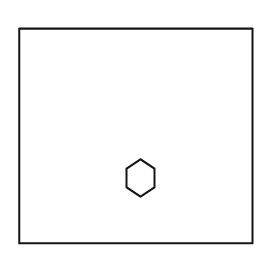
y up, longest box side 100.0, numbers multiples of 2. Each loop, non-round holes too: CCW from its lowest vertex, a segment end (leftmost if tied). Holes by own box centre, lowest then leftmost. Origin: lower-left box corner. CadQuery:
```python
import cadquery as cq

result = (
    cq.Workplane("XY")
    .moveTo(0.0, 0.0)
    .lineTo(100.0, 0.0)
    .lineTo(100.0, 92.0)
    .lineTo(0.0, 92.0)
    .close()
    .moveTo(52.0, 20.0)
    .lineTo(58.0, 24.0)
    .lineTo(58.0, 32.0)
    .lineTo(52.0, 36.0)
    .lineTo(46.0, 32.0)
    .lineTo(46.0, 24.0)
    .close()
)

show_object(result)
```